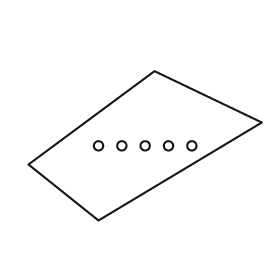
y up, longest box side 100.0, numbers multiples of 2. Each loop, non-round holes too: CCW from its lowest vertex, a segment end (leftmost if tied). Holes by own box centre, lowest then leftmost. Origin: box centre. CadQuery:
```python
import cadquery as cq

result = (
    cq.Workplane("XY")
    .moveTo(-20.0, -32.0)
    .lineTo(50.0, 10.0)
    .lineTo(4.0, 32.0)
    .lineTo(-50.0, -8.0)
    .close()
    .moveTo(-20.0, 0.0)
    .circle(2.0)
    .moveTo(-10.0, 0.0)
    .circle(2.0)
    .moveTo(0.0, 0.0)
    .circle(2.0)
    .moveTo(10.0, 0.0)
    .circle(2.0)
    .moveTo(20.0, 0.0)
    .circle(2.0)
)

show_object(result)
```